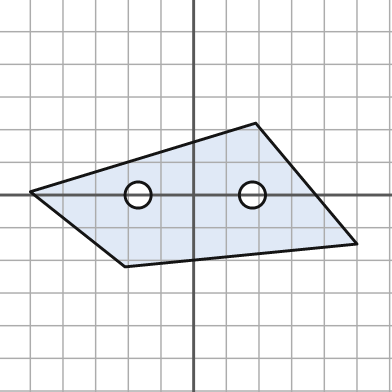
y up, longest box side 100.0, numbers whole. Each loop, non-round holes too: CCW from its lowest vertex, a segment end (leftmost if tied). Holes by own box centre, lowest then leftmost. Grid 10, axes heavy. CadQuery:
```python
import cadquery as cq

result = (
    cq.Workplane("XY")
    .moveTo(-21.0, -22.0)
    .lineTo(50.0, -15.0)
    .lineTo(19.0, 22.0)
    .lineTo(-50.0, 1.0)
    .close()
    .moveTo(-17.0, 0.0)
    .circle(4.0)
    .moveTo(18.0, 0.0)
    .circle(4.0)
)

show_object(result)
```